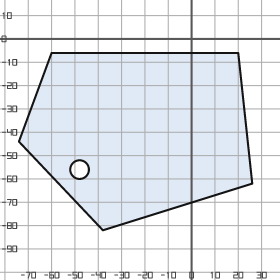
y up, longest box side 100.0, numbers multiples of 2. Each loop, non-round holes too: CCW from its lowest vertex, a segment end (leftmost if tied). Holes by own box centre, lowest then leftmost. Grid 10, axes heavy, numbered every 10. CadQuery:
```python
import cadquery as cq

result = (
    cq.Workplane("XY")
    .moveTo(-38.0, -82.0)
    .lineTo(26.0, -62.0)
    .lineTo(20.0, -6.0)
    .lineTo(-60.0, -6.0)
    .lineTo(-74.0, -44.0)
    .close()
    .moveTo(-48.0, -56.0)
    .circle(4.0)
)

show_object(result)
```